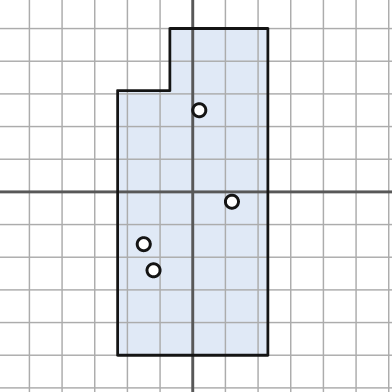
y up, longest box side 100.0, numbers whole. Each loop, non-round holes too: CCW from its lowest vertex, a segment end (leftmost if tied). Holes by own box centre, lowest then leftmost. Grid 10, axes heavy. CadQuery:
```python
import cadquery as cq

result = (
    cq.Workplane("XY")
    .moveTo(-23.0, -50.0)
    .lineTo(23.0, -50.0)
    .lineTo(23.0, 50.0)
    .lineTo(-7.0, 50.0)
    .lineTo(-7.0, 31.0)
    .lineTo(-23.0, 31.0)
    .close()
    .moveTo(-12.0, -24.0)
    .circle(2.0)
    .moveTo(-15.0, -16.0)
    .circle(2.0)
    .moveTo(12.0, -3.0)
    .circle(2.0)
    .moveTo(2.0, 25.0)
    .circle(2.0)
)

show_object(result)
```